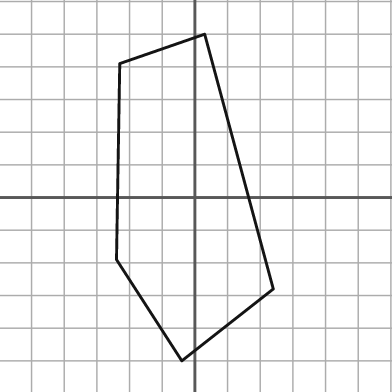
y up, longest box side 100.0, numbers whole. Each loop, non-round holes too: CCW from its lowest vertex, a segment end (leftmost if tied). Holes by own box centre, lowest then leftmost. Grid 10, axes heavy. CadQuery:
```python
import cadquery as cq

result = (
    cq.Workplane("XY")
    .moveTo(-4.0, -50.0)
    .lineTo(24.0, -28.0)
    .lineTo(3.0, 50.0)
    .lineTo(-23.0, 41.0)
    .lineTo(-24.0, -19.0)
    .close()
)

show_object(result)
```